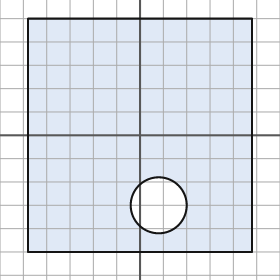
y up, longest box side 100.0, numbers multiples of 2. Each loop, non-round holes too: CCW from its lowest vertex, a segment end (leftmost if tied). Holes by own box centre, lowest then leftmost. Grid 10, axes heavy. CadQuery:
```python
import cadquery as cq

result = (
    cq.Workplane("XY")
    .moveTo(-48.0, -50.0)
    .lineTo(48.0, -50.0)
    .lineTo(48.0, 50.0)
    .lineTo(-48.0, 50.0)
    .close()
    .moveTo(8.0, -30.0)
    .circle(12.0)
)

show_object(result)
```